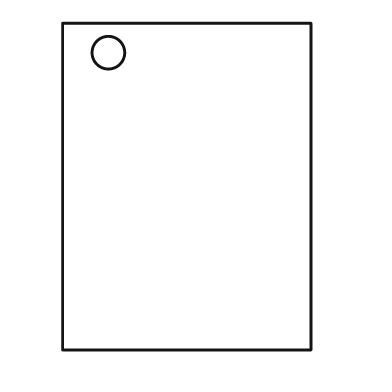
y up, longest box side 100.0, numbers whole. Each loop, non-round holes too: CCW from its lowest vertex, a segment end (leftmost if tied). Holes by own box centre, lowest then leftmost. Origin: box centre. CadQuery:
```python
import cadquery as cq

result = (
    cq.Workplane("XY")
    .moveTo(-38.0, -50.0)
    .lineTo(38.0, -50.0)
    .lineTo(38.0, 50.0)
    .lineTo(-38.0, 50.0)
    .close()
    .moveTo(-24.0, 41.0)
    .circle(5.0)
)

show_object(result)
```